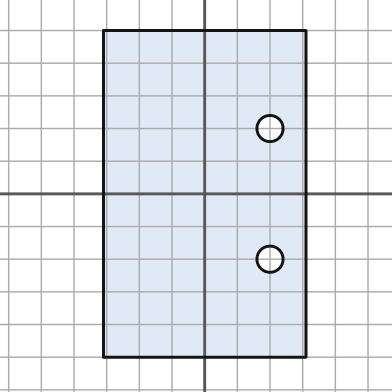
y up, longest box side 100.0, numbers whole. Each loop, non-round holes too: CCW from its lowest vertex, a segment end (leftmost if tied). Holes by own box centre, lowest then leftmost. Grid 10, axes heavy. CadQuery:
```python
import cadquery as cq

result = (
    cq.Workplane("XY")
    .moveTo(-31.0, -50.0)
    .lineTo(31.0, -50.0)
    .lineTo(31.0, 50.0)
    .lineTo(-31.0, 50.0)
    .close()
    .moveTo(20.0, -20.0)
    .circle(4.0)
    .moveTo(20.0, 20.0)
    .circle(4.0)
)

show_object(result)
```